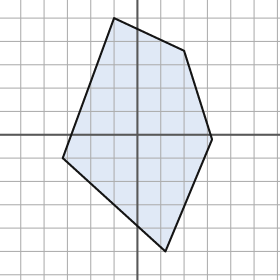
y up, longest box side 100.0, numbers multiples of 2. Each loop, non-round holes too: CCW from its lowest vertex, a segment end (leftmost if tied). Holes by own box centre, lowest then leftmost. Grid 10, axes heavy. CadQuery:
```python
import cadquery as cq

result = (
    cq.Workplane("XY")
    .moveTo(12.0, -50.0)
    .lineTo(32.0, -2.0)
    .lineTo(20.0, 36.0)
    .lineTo(-10.0, 50.0)
    .lineTo(-32.0, -10.0)
    .close()
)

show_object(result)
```